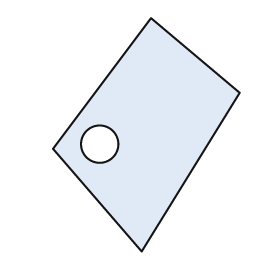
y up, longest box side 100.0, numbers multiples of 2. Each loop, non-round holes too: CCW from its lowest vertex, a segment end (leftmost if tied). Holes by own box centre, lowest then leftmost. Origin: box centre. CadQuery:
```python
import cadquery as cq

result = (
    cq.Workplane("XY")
    .moveTo(-2.0, -50.0)
    .lineTo(40.0, 18.0)
    .lineTo(2.0, 50.0)
    .lineTo(-40.0, -6.0)
    .close()
    .moveTo(-20.0, -4.0)
    .circle(8.0)
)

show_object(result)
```